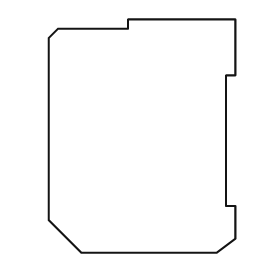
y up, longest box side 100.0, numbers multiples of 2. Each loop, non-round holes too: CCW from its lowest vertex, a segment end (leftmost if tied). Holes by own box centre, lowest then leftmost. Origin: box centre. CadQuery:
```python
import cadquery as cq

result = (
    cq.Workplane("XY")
    .moveTo(-26.0, -50.0)
    .lineTo(32.0, -50.0)
    .lineTo(40.0, -44.0)
    .lineTo(40.0, -30.0)
    .lineTo(36.0, -30.0)
    .lineTo(36.0, 26.0)
    .lineTo(40.0, 26.0)
    .lineTo(40.0, 50.0)
    .lineTo(-6.0, 50.0)
    .lineTo(-6.0, 46.0)
    .lineTo(-36.0, 46.0)
    .lineTo(-40.0, 42.0)
    .lineTo(-40.0, -36.0)
    .close()
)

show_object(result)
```